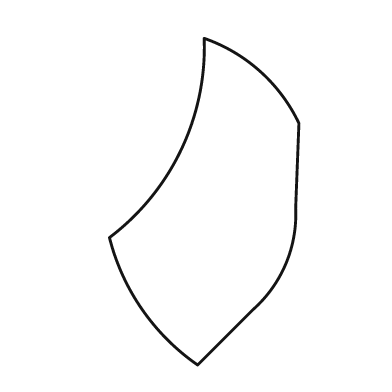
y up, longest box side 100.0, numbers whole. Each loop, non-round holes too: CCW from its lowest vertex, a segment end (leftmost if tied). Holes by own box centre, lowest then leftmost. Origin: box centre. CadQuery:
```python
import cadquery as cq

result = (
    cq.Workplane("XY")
    .moveTo(-2.0, -50.0)
    .lineTo(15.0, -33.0)
    .threePointArc((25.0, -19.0), (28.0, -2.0))
    .lineTo(29.0, 24.0)
    .threePointArc((17.0, 40.0), (0.0, 50.0))
    .threePointArc((-7.0, 16.0), (-29.0, -11.0))
    .threePointArc((-19.0, -33.0), (-2.0, -50.0))
    .close()
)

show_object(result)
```